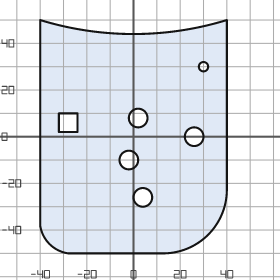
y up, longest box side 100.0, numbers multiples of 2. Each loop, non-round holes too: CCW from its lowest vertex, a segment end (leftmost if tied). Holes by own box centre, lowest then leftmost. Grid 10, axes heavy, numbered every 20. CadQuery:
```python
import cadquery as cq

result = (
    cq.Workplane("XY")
    .moveTo(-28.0, -50.0)
    .lineTo(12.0, -50.0)
    .threePointArc((32.0, -42.0), (40.0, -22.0))
    .lineTo(40.0, 50.0)
    .threePointArc((0.0, 44.0), (-40.0, 50.0))
    .lineTo(-40.0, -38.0)
    .threePointArc((-36.0, -46.0), (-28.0, -50.0))
    .close()
    .moveTo(4.0, -26.0)
    .circle(4.0)
    .moveTo(-2.0, -10.0)
    .circle(4.0)
    .moveTo(26.0, 0.0)
    .circle(4.0)
    .moveTo(-32.0, 2.0)
    .lineTo(-24.0, 2.0)
    .lineTo(-24.0, 10.0)
    .lineTo(-32.0, 10.0)
    .close()
    .moveTo(2.0, 8.0)
    .circle(4.0)
    .moveTo(30.0, 30.0)
    .circle(2.0)
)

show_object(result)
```